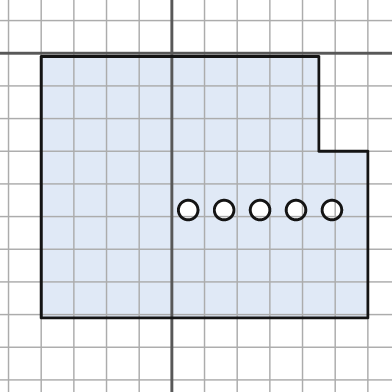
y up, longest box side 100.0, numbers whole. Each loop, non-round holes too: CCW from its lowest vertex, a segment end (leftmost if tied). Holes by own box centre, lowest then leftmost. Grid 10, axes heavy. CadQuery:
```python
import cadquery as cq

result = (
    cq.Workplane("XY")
    .moveTo(-40.0, -81.0)
    .lineTo(60.0, -81.0)
    .lineTo(60.0, -30.0)
    .lineTo(45.0, -30.0)
    .lineTo(45.0, -1.0)
    .lineTo(-40.0, -1.0)
    .close()
    .moveTo(5.0, -48.0)
    .circle(3.0)
    .moveTo(16.0, -48.0)
    .circle(3.0)
    .moveTo(27.0, -48.0)
    .circle(3.0)
    .moveTo(38.0, -48.0)
    .circle(3.0)
    .moveTo(49.0, -48.0)
    .circle(3.0)
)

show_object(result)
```